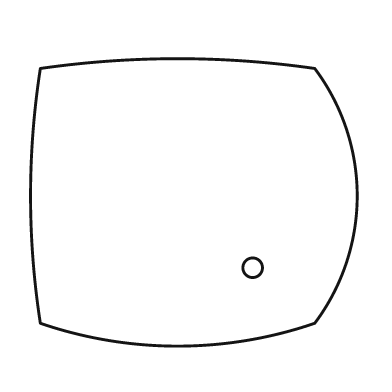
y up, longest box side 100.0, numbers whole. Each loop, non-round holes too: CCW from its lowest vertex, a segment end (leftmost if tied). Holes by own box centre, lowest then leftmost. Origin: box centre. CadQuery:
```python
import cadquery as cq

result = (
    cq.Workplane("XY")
    .moveTo(-47.0, -37.0)
    .threePointArc((-5.0, -44.0), (37.0, -37.0))
    .threePointArc((50.0, 2.0), (37.0, 41.0))
    .threePointArc((-5.0, 44.0), (-47.0, 41.0))
    .threePointArc((-50.0, 2.0), (-47.0, -37.0))
    .close()
    .moveTo(18.0, -20.0)
    .circle(3.0)
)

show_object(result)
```